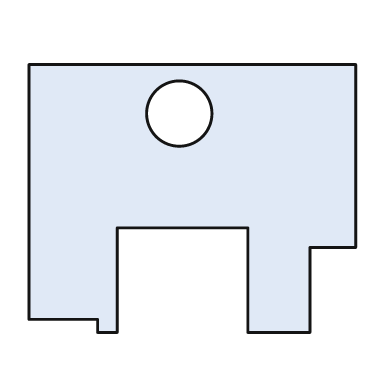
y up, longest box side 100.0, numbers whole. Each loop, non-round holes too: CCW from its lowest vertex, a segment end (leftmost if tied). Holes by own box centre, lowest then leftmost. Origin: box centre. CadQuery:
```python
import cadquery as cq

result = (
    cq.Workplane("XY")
    .moveTo(-29.0, -41.0)
    .lineTo(-23.0, -41.0)
    .lineTo(-23.0, -9.0)
    .lineTo(17.0, -9.0)
    .lineTo(17.0, -41.0)
    .lineTo(36.0, -41.0)
    .lineTo(36.0, -15.0)
    .lineTo(50.0, -15.0)
    .lineTo(50.0, 41.0)
    .lineTo(-50.0, 41.0)
    .lineTo(-50.0, -37.0)
    .lineTo(-29.0, -37.0)
    .close()
    .moveTo(-4.0, 26.0)
    .circle(10.0)
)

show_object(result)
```